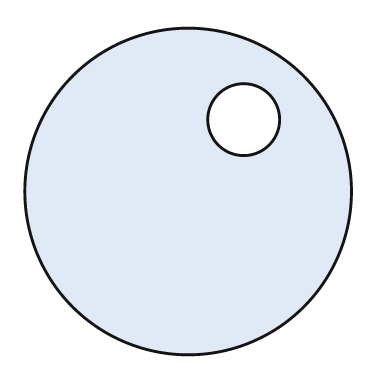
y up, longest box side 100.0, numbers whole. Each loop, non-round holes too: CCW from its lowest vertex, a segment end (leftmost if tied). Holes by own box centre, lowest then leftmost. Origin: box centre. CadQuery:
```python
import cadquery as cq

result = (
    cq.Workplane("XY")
    .moveTo(0.0, 0.0)
    .circle(50.0)
    .moveTo(17.0, 22.0)
    .circle(11.0)
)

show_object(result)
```